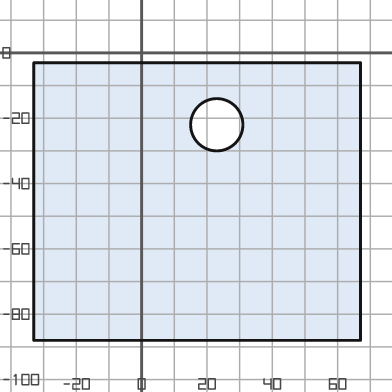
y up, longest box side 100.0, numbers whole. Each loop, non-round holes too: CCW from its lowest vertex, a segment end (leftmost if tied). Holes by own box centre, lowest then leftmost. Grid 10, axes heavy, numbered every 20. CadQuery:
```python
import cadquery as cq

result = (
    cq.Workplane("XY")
    .moveTo(-33.0, -88.0)
    .lineTo(67.0, -88.0)
    .lineTo(67.0, -3.0)
    .lineTo(-33.0, -3.0)
    .close()
    .moveTo(23.0, -22.0)
    .circle(8.0)
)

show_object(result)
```